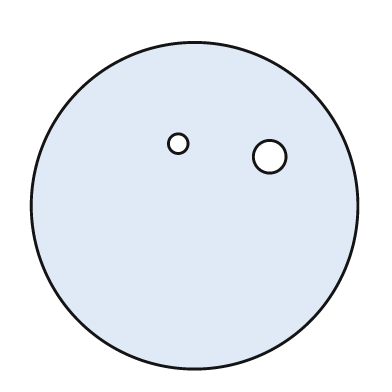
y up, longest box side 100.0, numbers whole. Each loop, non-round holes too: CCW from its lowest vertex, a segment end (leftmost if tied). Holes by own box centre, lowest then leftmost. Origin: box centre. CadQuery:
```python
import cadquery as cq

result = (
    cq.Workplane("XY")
    .moveTo(0.0, 0.0)
    .circle(50.0)
    .moveTo(23.0, 15.0)
    .circle(5.0)
    .moveTo(-5.0, 19.0)
    .circle(3.0)
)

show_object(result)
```